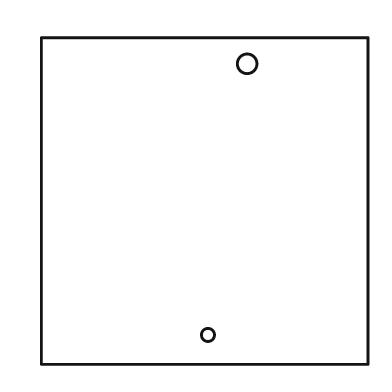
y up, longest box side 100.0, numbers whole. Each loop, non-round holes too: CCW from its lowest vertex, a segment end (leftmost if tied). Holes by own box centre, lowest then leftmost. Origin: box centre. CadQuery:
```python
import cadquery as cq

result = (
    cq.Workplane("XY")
    .moveTo(-50.0, -50.0)
    .lineTo(50.0, -50.0)
    .lineTo(50.0, 50.0)
    .lineTo(-50.0, 50.0)
    .close()
    .moveTo(1.0, -41.0)
    .circle(2.0)
    .moveTo(13.0, 42.0)
    .circle(3.0)
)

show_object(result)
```